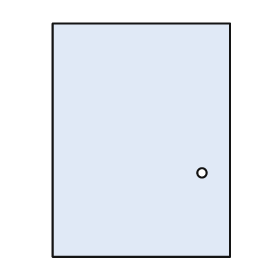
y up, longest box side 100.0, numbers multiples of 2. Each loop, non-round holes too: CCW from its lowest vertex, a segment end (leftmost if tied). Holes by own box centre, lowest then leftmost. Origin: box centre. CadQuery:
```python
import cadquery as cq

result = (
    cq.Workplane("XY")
    .moveTo(-38.0, -50.0)
    .lineTo(38.0, -50.0)
    .lineTo(38.0, 50.0)
    .lineTo(-38.0, 50.0)
    .close()
    .moveTo(26.0, -14.0)
    .circle(2.0)
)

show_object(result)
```